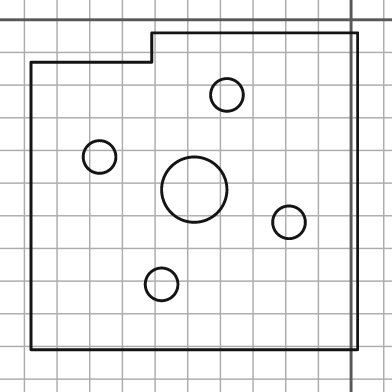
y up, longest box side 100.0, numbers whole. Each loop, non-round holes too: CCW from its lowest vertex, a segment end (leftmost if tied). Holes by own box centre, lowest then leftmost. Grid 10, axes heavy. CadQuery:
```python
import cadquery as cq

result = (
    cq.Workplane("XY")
    .moveTo(-98.0, -101.0)
    .lineTo(2.0, -101.0)
    .lineTo(2.0, -4.0)
    .lineTo(-61.0, -4.0)
    .lineTo(-61.0, -13.0)
    .lineTo(-98.0, -13.0)
    .close()
    .moveTo(-58.0, -81.0)
    .circle(5.0)
    .moveTo(-19.0, -62.0)
    .circle(5.0)
    .moveTo(-48.0, -52.0)
    .circle(10.0)
    .moveTo(-77.0, -42.0)
    .circle(5.0)
    .moveTo(-38.0, -23.0)
    .circle(5.0)
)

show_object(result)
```